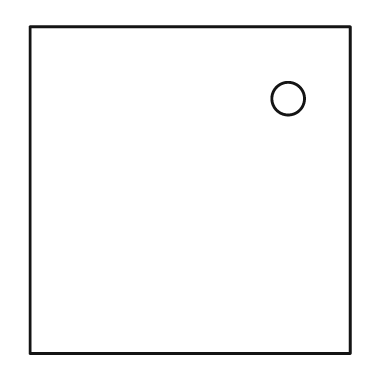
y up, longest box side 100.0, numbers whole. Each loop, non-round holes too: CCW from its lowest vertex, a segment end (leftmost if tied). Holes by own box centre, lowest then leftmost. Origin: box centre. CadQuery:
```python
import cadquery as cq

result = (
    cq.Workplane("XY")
    .moveTo(-49.0, -50.0)
    .lineTo(49.0, -50.0)
    .lineTo(49.0, 50.0)
    .lineTo(-49.0, 50.0)
    .close()
    .moveTo(30.0, 28.0)
    .circle(5.0)
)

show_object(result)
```